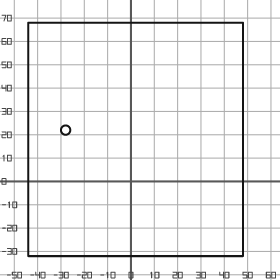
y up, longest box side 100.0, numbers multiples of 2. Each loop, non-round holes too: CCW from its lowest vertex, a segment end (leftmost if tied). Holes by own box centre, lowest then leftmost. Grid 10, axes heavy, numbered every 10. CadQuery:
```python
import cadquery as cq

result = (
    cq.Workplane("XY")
    .moveTo(-44.0, -32.0)
    .lineTo(48.0, -32.0)
    .lineTo(48.0, 68.0)
    .lineTo(-44.0, 68.0)
    .close()
    .moveTo(-28.0, 22.0)
    .circle(2.0)
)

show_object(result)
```